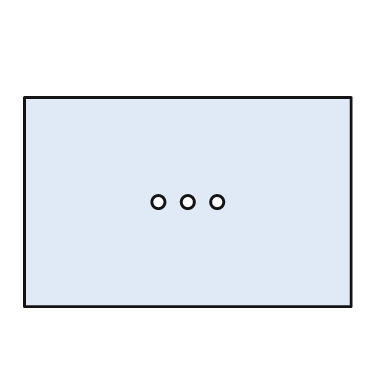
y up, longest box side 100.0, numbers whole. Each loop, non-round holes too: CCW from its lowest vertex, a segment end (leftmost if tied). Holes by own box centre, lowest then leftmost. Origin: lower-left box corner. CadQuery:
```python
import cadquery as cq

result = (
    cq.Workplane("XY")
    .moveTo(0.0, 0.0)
    .lineTo(100.0, 0.0)
    .lineTo(100.0, 64.0)
    .lineTo(0.0, 64.0)
    .close()
    .moveTo(41.0, 32.0)
    .circle(2.0)
    .moveTo(50.0, 32.0)
    .circle(2.0)
    .moveTo(59.0, 32.0)
    .circle(2.0)
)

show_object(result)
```